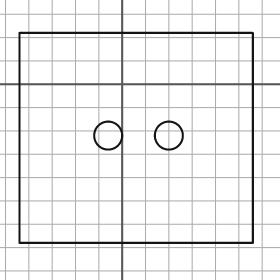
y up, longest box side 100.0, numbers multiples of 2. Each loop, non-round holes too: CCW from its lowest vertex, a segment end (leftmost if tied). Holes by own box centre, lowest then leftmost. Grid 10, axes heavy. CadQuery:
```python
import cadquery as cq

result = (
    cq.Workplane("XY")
    .moveTo(-44.0, -68.0)
    .lineTo(56.0, -68.0)
    .lineTo(56.0, 22.0)
    .lineTo(-44.0, 22.0)
    .close()
    .moveTo(-6.0, -22.0)
    .circle(6.0)
    .moveTo(20.0, -22.0)
    .circle(6.0)
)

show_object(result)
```